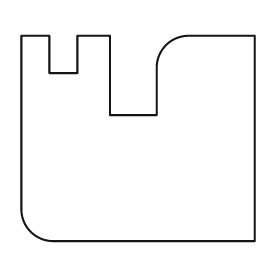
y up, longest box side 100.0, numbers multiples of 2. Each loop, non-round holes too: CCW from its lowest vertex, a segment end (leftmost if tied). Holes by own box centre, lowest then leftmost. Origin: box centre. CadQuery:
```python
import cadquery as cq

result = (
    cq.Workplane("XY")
    .moveTo(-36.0, -44.0)
    .lineTo(50.0, -44.0)
    .lineTo(50.0, 44.0)
    .lineTo(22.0, 44.0)
    .threePointArc((12.0, 40.0), (8.0, 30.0))
    .lineTo(8.0, 10.0)
    .lineTo(-12.0, 10.0)
    .lineTo(-12.0, 44.0)
    .lineTo(-26.0, 44.0)
    .lineTo(-26.0, 28.0)
    .lineTo(-38.0, 28.0)
    .lineTo(-38.0, 44.0)
    .lineTo(-50.0, 44.0)
    .lineTo(-50.0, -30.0)
    .threePointArc((-46.0, -40.0), (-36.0, -44.0))
    .close()
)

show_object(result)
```